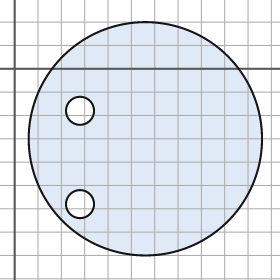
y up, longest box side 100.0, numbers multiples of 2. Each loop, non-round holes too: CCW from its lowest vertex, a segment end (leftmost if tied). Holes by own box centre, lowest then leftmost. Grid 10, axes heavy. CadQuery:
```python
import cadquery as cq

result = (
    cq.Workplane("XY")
    .moveTo(56.0, -30.0)
    .circle(50.0)
    .moveTo(28.0, -58.0)
    .circle(6.0)
    .moveTo(28.0, -18.0)
    .circle(6.0)
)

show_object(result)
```